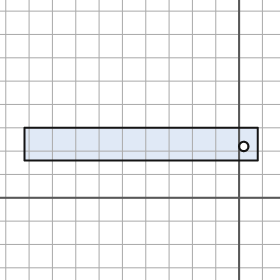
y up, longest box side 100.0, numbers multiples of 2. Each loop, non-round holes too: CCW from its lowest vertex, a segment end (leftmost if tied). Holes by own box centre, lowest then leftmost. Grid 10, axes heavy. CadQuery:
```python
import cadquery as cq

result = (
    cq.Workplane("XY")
    .moveTo(-92.0, 16.0)
    .lineTo(8.0, 16.0)
    .lineTo(8.0, 30.0)
    .lineTo(-92.0, 30.0)
    .close()
    .moveTo(2.0, 22.0)
    .circle(2.0)
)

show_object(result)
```